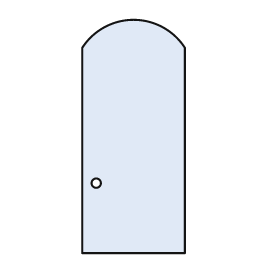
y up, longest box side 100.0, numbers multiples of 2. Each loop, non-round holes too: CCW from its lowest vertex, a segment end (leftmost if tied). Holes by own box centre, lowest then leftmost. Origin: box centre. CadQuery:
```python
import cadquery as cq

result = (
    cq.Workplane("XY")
    .moveTo(-22.0, -50.0)
    .lineTo(22.0, -50.0)
    .lineTo(22.0, 38.0)
    .threePointArc((0.0, 50.0), (-22.0, 38.0))
    .close()
    .moveTo(-16.0, -20.0)
    .circle(2.0)
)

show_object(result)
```